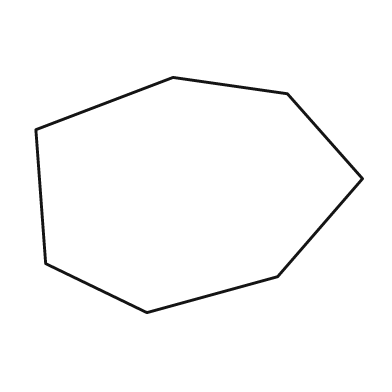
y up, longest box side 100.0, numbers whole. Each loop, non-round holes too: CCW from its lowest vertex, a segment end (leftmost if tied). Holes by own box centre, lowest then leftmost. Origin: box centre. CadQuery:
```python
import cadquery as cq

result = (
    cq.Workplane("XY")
    .moveTo(-16.0, -36.0)
    .lineTo(24.0, -25.0)
    .lineTo(50.0, 5.0)
    .lineTo(27.0, 31.0)
    .lineTo(-8.0, 36.0)
    .lineTo(-50.0, 20.0)
    .lineTo(-47.0, -21.0)
    .close()
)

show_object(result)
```